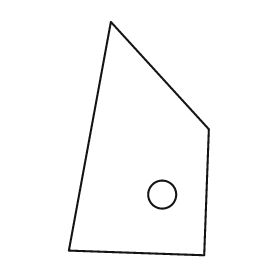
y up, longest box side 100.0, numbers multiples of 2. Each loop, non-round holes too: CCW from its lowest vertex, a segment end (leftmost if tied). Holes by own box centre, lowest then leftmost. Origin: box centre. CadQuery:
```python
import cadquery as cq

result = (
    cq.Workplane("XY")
    .moveTo(28.0, -50.0)
    .lineTo(30.0, 4.0)
    .lineTo(-12.0, 50.0)
    .lineTo(-30.0, -48.0)
    .close()
    .moveTo(10.0, -24.0)
    .circle(6.0)
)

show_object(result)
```